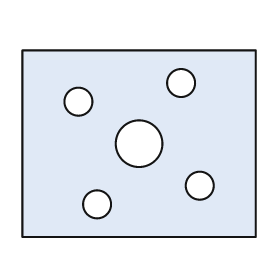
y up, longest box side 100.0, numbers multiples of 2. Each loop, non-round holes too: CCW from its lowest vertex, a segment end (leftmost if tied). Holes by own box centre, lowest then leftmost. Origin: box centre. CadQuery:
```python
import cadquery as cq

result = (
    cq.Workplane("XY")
    .moveTo(-50.0, -40.0)
    .lineTo(50.0, -40.0)
    .lineTo(50.0, 40.0)
    .lineTo(-50.0, 40.0)
    .close()
    .moveTo(-18.0, -26.0)
    .circle(6.0)
    .moveTo(26.0, -18.0)
    .circle(6.0)
    .moveTo(0.0, 0.0)
    .circle(10.0)
    .moveTo(-26.0, 18.0)
    .circle(6.0)
    .moveTo(18.0, 26.0)
    .circle(6.0)
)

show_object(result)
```